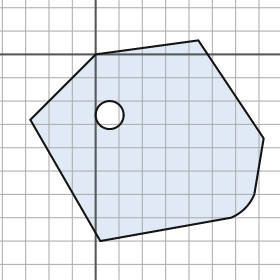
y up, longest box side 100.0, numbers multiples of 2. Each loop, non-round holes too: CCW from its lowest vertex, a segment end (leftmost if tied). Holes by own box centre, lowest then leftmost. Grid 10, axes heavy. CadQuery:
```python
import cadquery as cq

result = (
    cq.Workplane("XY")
    .moveTo(2.0, -80.0)
    .lineTo(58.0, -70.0)
    .threePointArc((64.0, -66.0), (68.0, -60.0))
    .lineTo(72.0, -36.0)
    .lineTo(44.0, 6.0)
    .lineTo(0.0, 0.0)
    .lineTo(-28.0, -28.0)
    .close()
    .moveTo(6.0, -26.0)
    .circle(6.0)
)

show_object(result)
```